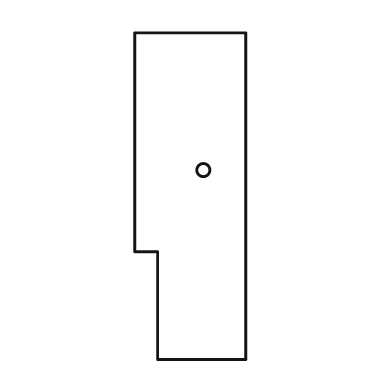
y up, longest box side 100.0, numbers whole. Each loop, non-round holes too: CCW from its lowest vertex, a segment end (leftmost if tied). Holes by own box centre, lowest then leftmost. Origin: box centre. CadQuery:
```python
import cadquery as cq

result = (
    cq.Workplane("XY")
    .moveTo(-10.0, -50.0)
    .lineTo(17.0, -50.0)
    .lineTo(17.0, 50.0)
    .lineTo(-17.0, 50.0)
    .lineTo(-17.0, -17.0)
    .lineTo(-10.0, -17.0)
    .close()
    .moveTo(4.0, 8.0)
    .circle(2.0)
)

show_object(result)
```